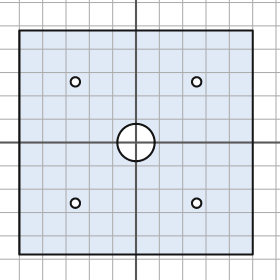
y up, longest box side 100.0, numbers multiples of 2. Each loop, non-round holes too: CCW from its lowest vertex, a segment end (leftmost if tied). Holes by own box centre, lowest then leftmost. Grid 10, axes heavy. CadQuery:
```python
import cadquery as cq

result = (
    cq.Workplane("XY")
    .moveTo(-50.0, -48.0)
    .lineTo(50.0, -48.0)
    .lineTo(50.0, 48.0)
    .lineTo(-50.0, 48.0)
    .close()
    .moveTo(-26.0, -26.0)
    .circle(2.0)
    .moveTo(26.0, -26.0)
    .circle(2.0)
    .moveTo(0.0, 0.0)
    .circle(8.0)
    .moveTo(-26.0, 26.0)
    .circle(2.0)
    .moveTo(26.0, 26.0)
    .circle(2.0)
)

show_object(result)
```